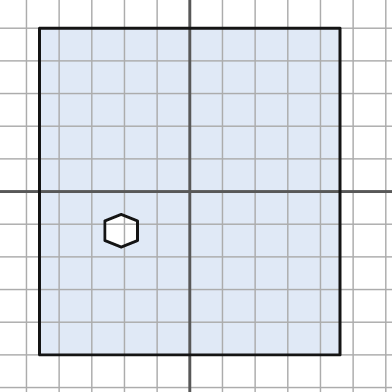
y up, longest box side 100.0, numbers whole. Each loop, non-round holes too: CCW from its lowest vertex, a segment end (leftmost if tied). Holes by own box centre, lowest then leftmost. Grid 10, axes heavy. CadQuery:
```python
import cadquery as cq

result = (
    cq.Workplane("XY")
    .moveTo(-46.0, -50.0)
    .lineTo(46.0, -50.0)
    .lineTo(46.0, 50.0)
    .lineTo(-46.0, 50.0)
    .close()
    .moveTo(-21.0, -17.0)
    .lineTo(-16.0, -15.0)
    .lineTo(-16.0, -9.0)
    .lineTo(-21.0, -7.0)
    .lineTo(-26.0, -9.0)
    .lineTo(-26.0, -15.0)
    .close()
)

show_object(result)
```